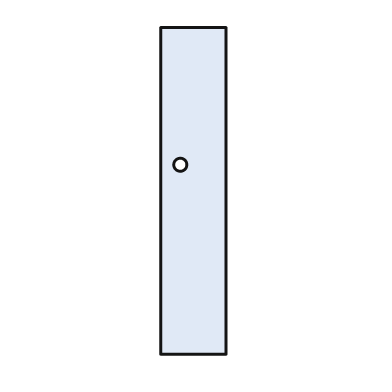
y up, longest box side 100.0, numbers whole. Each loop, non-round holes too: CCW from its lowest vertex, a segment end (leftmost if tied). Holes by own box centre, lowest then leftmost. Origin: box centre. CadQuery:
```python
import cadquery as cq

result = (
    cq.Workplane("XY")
    .moveTo(-10.0, -50.0)
    .lineTo(10.0, -50.0)
    .lineTo(10.0, 50.0)
    .lineTo(-10.0, 50.0)
    .close()
    .moveTo(-4.0, 8.0)
    .circle(2.0)
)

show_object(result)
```